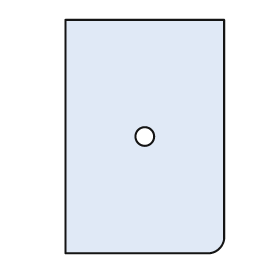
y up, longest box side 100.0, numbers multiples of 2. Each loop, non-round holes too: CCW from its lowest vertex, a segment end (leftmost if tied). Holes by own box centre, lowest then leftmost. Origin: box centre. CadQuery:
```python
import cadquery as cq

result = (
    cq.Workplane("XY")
    .moveTo(-34.0, -50.0)
    .lineTo(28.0, -50.0)
    .threePointArc((32.0, -48.0), (34.0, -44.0))
    .lineTo(34.0, 50.0)
    .lineTo(-34.0, 50.0)
    .close()
    .moveTo(0.0, 0.0)
    .circle(4.0)
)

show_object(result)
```